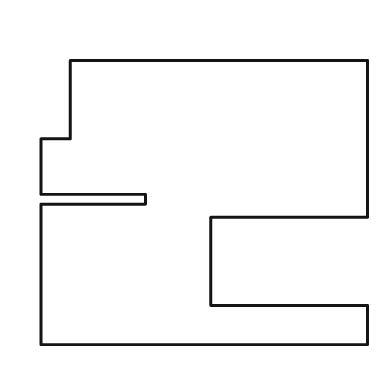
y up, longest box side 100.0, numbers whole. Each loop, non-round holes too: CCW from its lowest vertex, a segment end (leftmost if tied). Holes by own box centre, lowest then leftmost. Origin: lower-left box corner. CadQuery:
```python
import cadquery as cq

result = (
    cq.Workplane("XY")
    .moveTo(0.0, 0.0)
    .lineTo(100.0, 0.0)
    .lineTo(100.0, 12.0)
    .lineTo(52.0, 12.0)
    .lineTo(52.0, 39.0)
    .lineTo(100.0, 39.0)
    .lineTo(100.0, 87.0)
    .lineTo(9.0, 87.0)
    .lineTo(9.0, 63.0)
    .lineTo(0.0, 63.0)
    .lineTo(0.0, 46.0)
    .lineTo(32.0, 46.0)
    .lineTo(32.0, 43.0)
    .lineTo(0.0, 43.0)
    .close()
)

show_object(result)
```